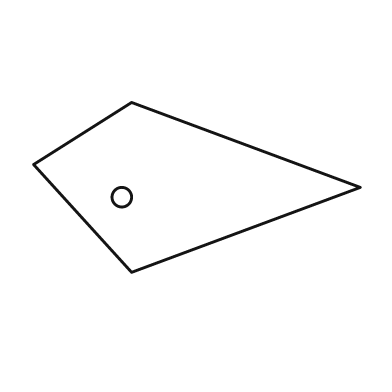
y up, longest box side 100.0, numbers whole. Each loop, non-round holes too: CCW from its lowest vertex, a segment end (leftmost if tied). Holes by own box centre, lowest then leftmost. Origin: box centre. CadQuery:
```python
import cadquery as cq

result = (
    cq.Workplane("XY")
    .moveTo(-20.0, -26.0)
    .lineTo(50.0, 0.0)
    .lineTo(-20.0, 26.0)
    .lineTo(-50.0, 7.0)
    .close()
    .moveTo(-23.0, -3.0)
    .circle(3.0)
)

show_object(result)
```